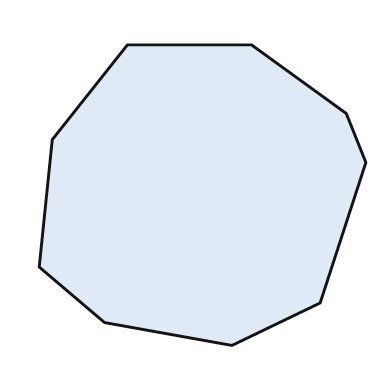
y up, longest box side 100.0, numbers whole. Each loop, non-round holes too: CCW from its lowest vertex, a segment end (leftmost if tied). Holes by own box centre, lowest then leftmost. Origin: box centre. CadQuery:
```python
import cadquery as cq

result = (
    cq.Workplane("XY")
    .moveTo(9.0, -46.0)
    .lineTo(36.0, -33.0)
    .lineTo(50.0, 10.0)
    .lineTo(44.0, 25.0)
    .lineTo(15.0, 46.0)
    .lineTo(-23.0, 46.0)
    .lineTo(-46.0, 17.0)
    .lineTo(-50.0, -22.0)
    .lineTo(-30.0, -39.0)
    .close()
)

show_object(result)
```